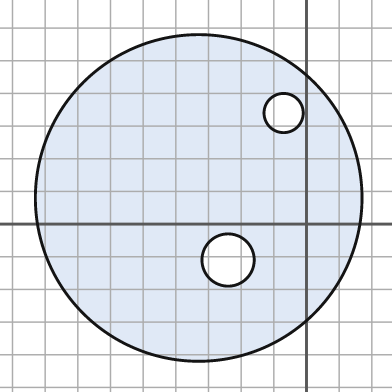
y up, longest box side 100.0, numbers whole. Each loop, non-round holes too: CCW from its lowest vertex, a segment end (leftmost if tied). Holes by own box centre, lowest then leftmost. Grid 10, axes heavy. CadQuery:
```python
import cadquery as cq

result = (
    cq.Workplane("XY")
    .moveTo(-33.0, 8.0)
    .circle(50.0)
    .moveTo(-24.0, -11.0)
    .circle(8.0)
    .moveTo(-7.0, 34.0)
    .circle(6.0)
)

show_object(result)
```